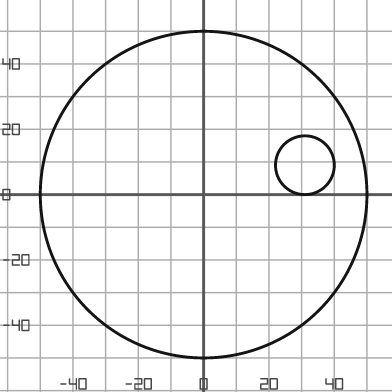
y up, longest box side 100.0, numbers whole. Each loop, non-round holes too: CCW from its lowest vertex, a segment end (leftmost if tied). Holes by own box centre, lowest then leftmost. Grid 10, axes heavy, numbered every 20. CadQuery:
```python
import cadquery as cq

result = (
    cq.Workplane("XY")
    .moveTo(0.0, 0.0)
    .circle(50.0)
    .moveTo(31.0, 9.0)
    .circle(9.0)
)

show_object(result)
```